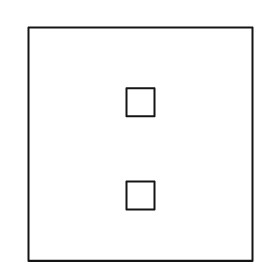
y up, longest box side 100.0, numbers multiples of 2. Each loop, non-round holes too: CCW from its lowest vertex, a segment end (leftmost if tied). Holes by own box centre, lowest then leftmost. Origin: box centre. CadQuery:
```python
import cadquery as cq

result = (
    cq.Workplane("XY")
    .moveTo(-48.0, -50.0)
    .lineTo(48.0, -50.0)
    .lineTo(48.0, 50.0)
    .lineTo(-48.0, 50.0)
    .close()
    .moveTo(-6.0, -28.0)
    .lineTo(6.0, -28.0)
    .lineTo(6.0, -16.0)
    .lineTo(-6.0, -16.0)
    .close()
    .moveTo(-6.0, 12.0)
    .lineTo(6.0, 12.0)
    .lineTo(6.0, 24.0)
    .lineTo(-6.0, 24.0)
    .close()
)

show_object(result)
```